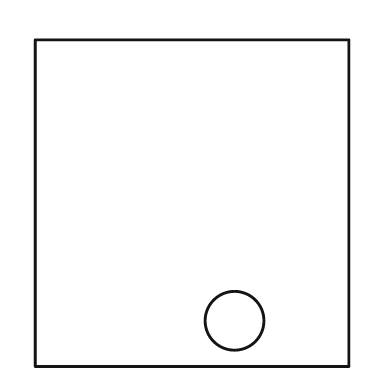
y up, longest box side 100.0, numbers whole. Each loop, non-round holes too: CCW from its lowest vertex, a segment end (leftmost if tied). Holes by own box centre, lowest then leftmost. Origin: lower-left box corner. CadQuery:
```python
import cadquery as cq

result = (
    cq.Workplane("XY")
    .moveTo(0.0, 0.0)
    .lineTo(96.0, 0.0)
    .lineTo(96.0, 100.0)
    .lineTo(0.0, 100.0)
    .close()
    .moveTo(61.0, 14.0)
    .circle(9.0)
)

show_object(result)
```